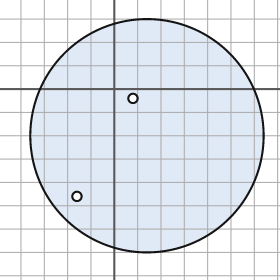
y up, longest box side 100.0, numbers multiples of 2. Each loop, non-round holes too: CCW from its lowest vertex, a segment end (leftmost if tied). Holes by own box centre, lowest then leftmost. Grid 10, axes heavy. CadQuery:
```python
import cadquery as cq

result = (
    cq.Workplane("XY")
    .moveTo(14.0, -20.0)
    .circle(50.0)
    .moveTo(-16.0, -46.0)
    .circle(2.0)
    .moveTo(8.0, -4.0)
    .circle(2.0)
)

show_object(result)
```